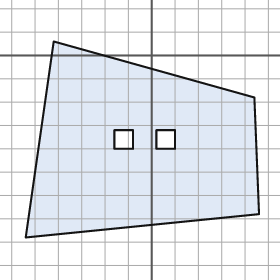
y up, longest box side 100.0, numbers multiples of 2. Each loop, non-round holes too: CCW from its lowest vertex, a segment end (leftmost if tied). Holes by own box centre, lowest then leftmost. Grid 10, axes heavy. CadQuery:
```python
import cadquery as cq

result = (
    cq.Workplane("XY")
    .moveTo(-54.0, -78.0)
    .lineTo(46.0, -68.0)
    .lineTo(44.0, -18.0)
    .lineTo(-42.0, 6.0)
    .close()
    .moveTo(-16.0, -40.0)
    .lineTo(-8.0, -40.0)
    .lineTo(-8.0, -32.0)
    .lineTo(-16.0, -32.0)
    .close()
    .moveTo(2.0, -40.0)
    .lineTo(10.0, -40.0)
    .lineTo(10.0, -32.0)
    .lineTo(2.0, -32.0)
    .close()
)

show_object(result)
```